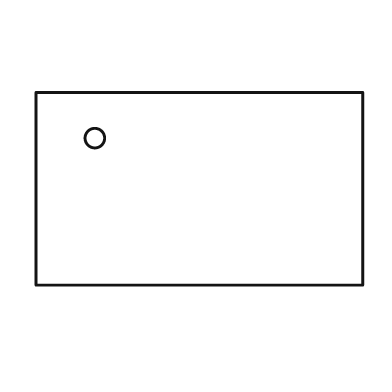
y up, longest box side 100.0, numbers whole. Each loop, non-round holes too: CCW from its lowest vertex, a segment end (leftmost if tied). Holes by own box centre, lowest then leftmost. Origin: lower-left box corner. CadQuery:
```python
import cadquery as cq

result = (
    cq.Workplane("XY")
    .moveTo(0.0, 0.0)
    .lineTo(100.0, 0.0)
    .lineTo(100.0, 59.0)
    .lineTo(0.0, 59.0)
    .close()
    .moveTo(18.0, 45.0)
    .circle(3.0)
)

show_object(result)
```